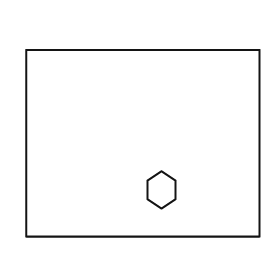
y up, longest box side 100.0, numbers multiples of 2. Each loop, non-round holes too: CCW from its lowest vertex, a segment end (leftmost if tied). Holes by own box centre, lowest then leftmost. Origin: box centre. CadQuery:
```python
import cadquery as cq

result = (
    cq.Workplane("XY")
    .moveTo(-50.0, -40.0)
    .lineTo(50.0, -40.0)
    .lineTo(50.0, 40.0)
    .lineTo(-50.0, 40.0)
    .close()
    .moveTo(8.0, -28.0)
    .lineTo(14.0, -24.0)
    .lineTo(14.0, -16.0)
    .lineTo(8.0, -12.0)
    .lineTo(2.0, -16.0)
    .lineTo(2.0, -24.0)
    .close()
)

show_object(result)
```